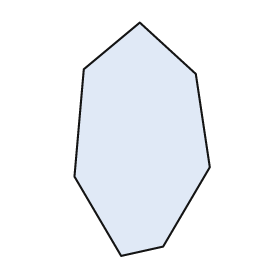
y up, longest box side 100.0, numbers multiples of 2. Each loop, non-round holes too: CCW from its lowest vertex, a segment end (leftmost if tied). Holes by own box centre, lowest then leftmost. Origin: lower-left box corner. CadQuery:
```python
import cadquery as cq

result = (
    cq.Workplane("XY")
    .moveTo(20.0, 0.0)
    .lineTo(38.0, 4.0)
    .lineTo(58.0, 38.0)
    .lineTo(52.0, 78.0)
    .lineTo(28.0, 100.0)
    .lineTo(4.0, 80.0)
    .lineTo(0.0, 34.0)
    .close()
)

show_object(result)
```